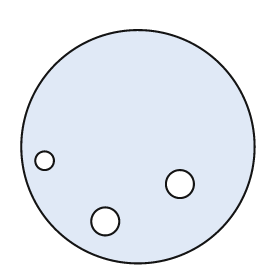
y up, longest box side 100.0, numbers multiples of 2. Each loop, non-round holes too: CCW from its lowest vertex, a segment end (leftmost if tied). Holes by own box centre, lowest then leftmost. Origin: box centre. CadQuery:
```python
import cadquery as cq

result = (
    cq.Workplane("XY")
    .moveTo(0.0, 0.0)
    .circle(50.0)
    .moveTo(-14.0, -32.0)
    .circle(6.0)
    .moveTo(18.0, -16.0)
    .circle(6.0)
    .moveTo(-40.0, -6.0)
    .circle(4.0)
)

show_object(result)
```